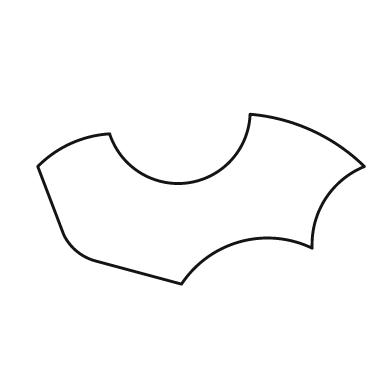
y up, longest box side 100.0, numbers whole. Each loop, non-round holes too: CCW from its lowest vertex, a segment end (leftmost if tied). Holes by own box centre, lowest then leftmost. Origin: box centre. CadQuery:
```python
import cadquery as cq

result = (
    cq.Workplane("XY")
    .moveTo(-6.0, -26.0)
    .threePointArc((12.0, -13.0), (34.0, -15.0))
    .threePointArc((38.0, 0.0), (50.0, 10.0))
    .threePointArc((34.0, 21.0), (15.0, 26.0))
    .threePointArc((-4.0, 5.0), (-28.0, 20.0))
    .threePointArc((-40.0, 17.0), (-50.0, 10.0))
    .lineTo(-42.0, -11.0)
    .threePointArc((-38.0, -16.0), (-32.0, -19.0))
    .close()
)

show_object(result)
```